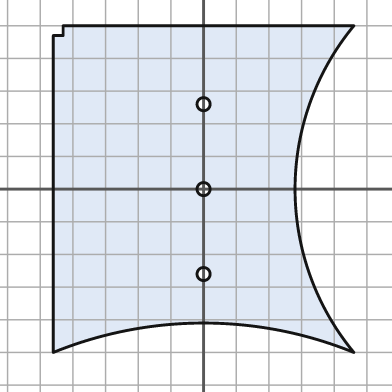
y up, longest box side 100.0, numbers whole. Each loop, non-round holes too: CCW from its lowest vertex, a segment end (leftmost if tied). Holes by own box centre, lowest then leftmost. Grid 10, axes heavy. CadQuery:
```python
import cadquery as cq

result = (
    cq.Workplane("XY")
    .moveTo(-46.0, -50.0)
    .threePointArc((0.0, -41.0), (46.0, -50.0))
    .threePointArc((28.0, 0.0), (46.0, 50.0))
    .lineTo(-43.0, 50.0)
    .lineTo(-43.0, 47.0)
    .lineTo(-46.0, 47.0)
    .close()
    .moveTo(0.0, -26.0)
    .circle(2.0)
    .moveTo(0.0, 0.0)
    .circle(2.0)
    .moveTo(0.0, 26.0)
    .circle(2.0)
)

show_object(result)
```